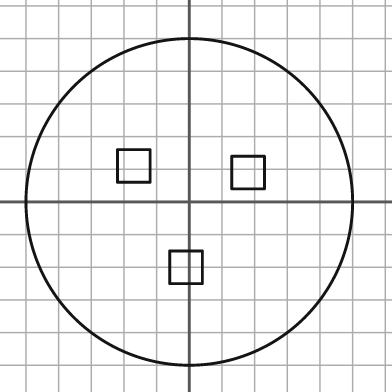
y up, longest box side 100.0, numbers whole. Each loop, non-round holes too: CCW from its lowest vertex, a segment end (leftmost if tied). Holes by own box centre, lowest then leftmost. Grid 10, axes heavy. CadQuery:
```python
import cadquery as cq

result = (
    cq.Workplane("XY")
    .moveTo(0.0, 0.0)
    .circle(50.0)
    .moveTo(-6.0, -25.0)
    .lineTo(4.0, -25.0)
    .lineTo(4.0, -15.0)
    .lineTo(-6.0, -15.0)
    .close()
    .moveTo(13.0, 4.0)
    .lineTo(23.0, 4.0)
    .lineTo(23.0, 14.0)
    .lineTo(13.0, 14.0)
    .close()
    .moveTo(-22.0, 6.0)
    .lineTo(-12.0, 6.0)
    .lineTo(-12.0, 16.0)
    .lineTo(-22.0, 16.0)
    .close()
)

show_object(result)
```